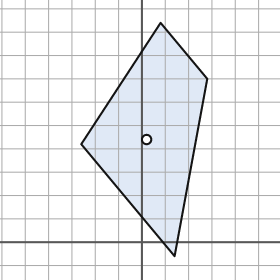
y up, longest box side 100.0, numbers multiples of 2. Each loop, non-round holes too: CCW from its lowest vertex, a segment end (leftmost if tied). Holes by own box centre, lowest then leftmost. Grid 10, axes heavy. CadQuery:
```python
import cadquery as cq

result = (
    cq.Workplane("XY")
    .moveTo(14.0, -6.0)
    .lineTo(28.0, 70.0)
    .lineTo(8.0, 94.0)
    .lineTo(-26.0, 42.0)
    .close()
    .moveTo(2.0, 44.0)
    .circle(2.0)
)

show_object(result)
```